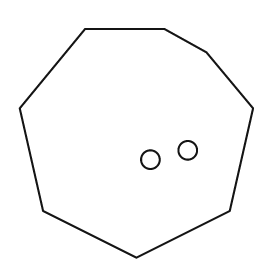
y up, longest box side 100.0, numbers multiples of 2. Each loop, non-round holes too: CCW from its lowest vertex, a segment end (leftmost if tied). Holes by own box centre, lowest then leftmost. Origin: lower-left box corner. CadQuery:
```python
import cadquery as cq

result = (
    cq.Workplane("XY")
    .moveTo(50.0, 0.0)
    .lineTo(90.0, 20.0)
    .lineTo(100.0, 64.0)
    .lineTo(80.0, 88.0)
    .lineTo(62.0, 98.0)
    .lineTo(28.0, 98.0)
    .lineTo(0.0, 64.0)
    .lineTo(10.0, 20.0)
    .close()
    .moveTo(56.0, 42.0)
    .circle(4.0)
    .moveTo(72.0, 46.0)
    .circle(4.0)
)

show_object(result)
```